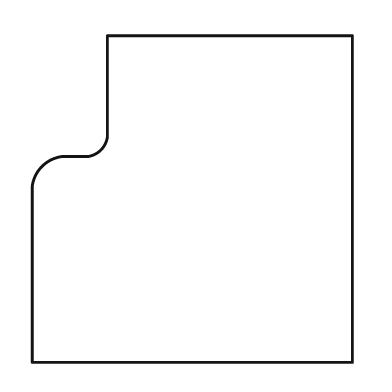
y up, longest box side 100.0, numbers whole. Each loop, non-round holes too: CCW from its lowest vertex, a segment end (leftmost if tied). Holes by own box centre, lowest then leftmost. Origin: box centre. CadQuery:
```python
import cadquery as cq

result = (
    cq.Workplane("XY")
    .moveTo(-49.0, -50.0)
    .lineTo(49.0, -50.0)
    .lineTo(49.0, 50.0)
    .lineTo(-26.0, 50.0)
    .lineTo(-26.0, 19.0)
    .threePointArc((-28.0, 15.0), (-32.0, 13.0))
    .lineTo(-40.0, 13.0)
    .threePointArc((-46.0, 10.0), (-49.0, 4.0))
    .close()
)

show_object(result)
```